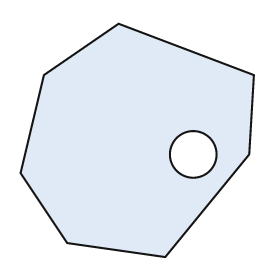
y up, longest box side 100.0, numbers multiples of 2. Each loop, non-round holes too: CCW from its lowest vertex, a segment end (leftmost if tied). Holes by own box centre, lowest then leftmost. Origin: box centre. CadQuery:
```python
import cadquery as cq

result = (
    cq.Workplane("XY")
    .moveTo(12.0, -50.0)
    .lineTo(48.0, -6.0)
    .lineTo(50.0, 28.0)
    .lineTo(-8.0, 50.0)
    .lineTo(-40.0, 28.0)
    .lineTo(-50.0, -14.0)
    .lineTo(-30.0, -44.0)
    .close()
    .moveTo(24.0, -6.0)
    .circle(10.0)
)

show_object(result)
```